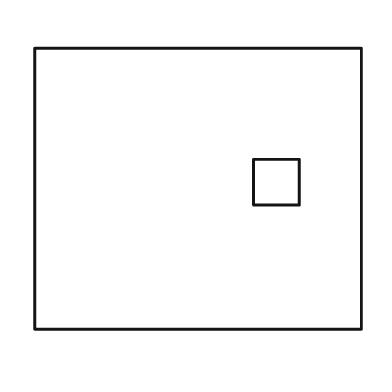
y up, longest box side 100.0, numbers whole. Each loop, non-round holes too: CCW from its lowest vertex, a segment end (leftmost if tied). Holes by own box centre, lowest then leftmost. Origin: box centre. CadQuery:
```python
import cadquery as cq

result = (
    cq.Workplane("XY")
    .moveTo(-50.0, -43.0)
    .lineTo(50.0, -43.0)
    .lineTo(50.0, 43.0)
    .lineTo(-50.0, 43.0)
    .close()
    .moveTo(17.0, -5.0)
    .lineTo(31.0, -5.0)
    .lineTo(31.0, 9.0)
    .lineTo(17.0, 9.0)
    .close()
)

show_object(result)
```